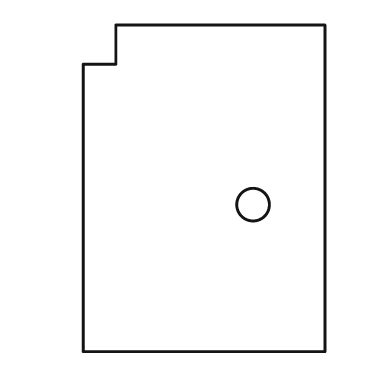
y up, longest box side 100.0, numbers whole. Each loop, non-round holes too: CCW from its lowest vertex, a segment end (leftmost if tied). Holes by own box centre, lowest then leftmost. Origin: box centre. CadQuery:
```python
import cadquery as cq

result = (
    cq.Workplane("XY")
    .moveTo(-37.0, -50.0)
    .lineTo(37.0, -50.0)
    .lineTo(37.0, 50.0)
    .lineTo(-27.0, 50.0)
    .lineTo(-27.0, 38.0)
    .lineTo(-37.0, 38.0)
    .close()
    .moveTo(15.0, -5.0)
    .circle(5.0)
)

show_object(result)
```